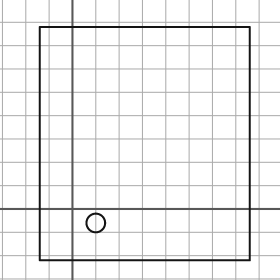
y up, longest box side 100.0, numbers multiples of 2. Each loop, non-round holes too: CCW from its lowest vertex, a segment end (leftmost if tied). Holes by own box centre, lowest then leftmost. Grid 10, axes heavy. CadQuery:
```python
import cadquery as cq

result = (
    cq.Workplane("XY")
    .moveTo(-14.0, -22.0)
    .lineTo(76.0, -22.0)
    .lineTo(76.0, 78.0)
    .lineTo(-14.0, 78.0)
    .close()
    .moveTo(10.0, -6.0)
    .circle(4.0)
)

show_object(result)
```